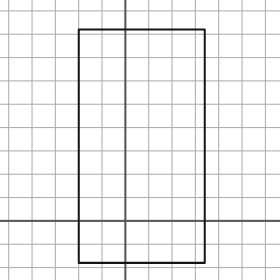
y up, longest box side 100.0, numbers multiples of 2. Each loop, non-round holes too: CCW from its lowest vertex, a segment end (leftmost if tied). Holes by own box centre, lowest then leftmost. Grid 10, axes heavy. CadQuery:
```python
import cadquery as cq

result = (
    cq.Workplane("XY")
    .moveTo(-20.0, -18.0)
    .lineTo(34.0, -18.0)
    .lineTo(34.0, 82.0)
    .lineTo(-20.0, 82.0)
    .close()
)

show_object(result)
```